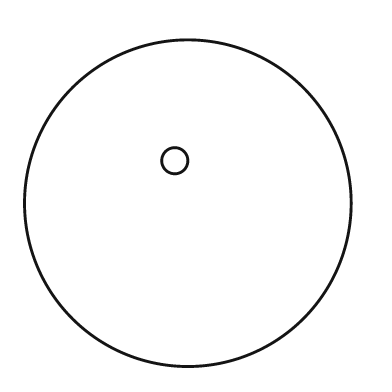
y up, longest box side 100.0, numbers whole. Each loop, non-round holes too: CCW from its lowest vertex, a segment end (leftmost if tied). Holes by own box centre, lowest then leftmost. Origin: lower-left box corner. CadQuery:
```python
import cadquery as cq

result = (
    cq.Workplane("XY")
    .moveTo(50.0, 50.0)
    .circle(50.0)
    .moveTo(46.0, 63.0)
    .circle(4.0)
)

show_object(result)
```